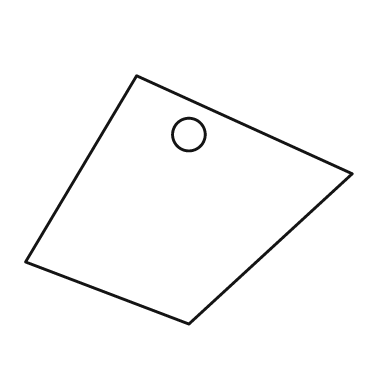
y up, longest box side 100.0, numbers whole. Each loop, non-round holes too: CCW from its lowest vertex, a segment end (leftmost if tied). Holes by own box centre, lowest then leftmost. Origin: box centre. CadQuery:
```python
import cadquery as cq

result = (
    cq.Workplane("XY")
    .moveTo(0.0, -38.0)
    .lineTo(50.0, 8.0)
    .lineTo(-16.0, 38.0)
    .lineTo(-50.0, -19.0)
    .close()
    .moveTo(0.0, 20.0)
    .circle(5.0)
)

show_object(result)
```